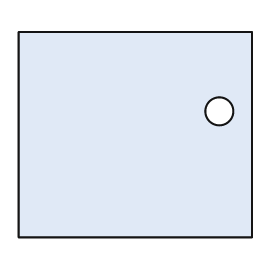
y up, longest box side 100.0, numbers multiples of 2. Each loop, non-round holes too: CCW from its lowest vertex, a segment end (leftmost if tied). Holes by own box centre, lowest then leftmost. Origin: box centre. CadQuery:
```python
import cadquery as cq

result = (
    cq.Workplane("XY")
    .moveTo(-50.0, -44.0)
    .lineTo(50.0, -44.0)
    .lineTo(50.0, 44.0)
    .lineTo(-50.0, 44.0)
    .close()
    .moveTo(36.0, 10.0)
    .circle(6.0)
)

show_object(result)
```